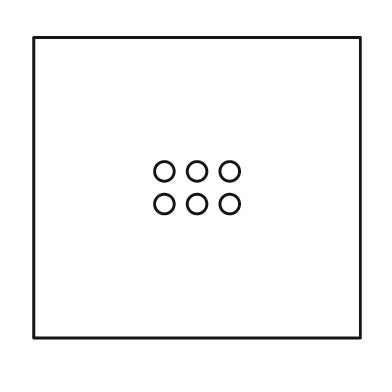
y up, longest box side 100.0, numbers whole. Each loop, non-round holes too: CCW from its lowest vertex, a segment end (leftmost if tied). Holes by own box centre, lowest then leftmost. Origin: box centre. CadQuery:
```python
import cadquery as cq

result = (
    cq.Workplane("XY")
    .moveTo(-50.0, -46.0)
    .lineTo(50.0, -46.0)
    .lineTo(50.0, 46.0)
    .lineTo(-50.0, 46.0)
    .close()
    .moveTo(-10.0, -5.0)
    .circle(3.0)
    .moveTo(0.0, -5.0)
    .circle(3.0)
    .moveTo(10.0, -5.0)
    .circle(3.0)
    .moveTo(-10.0, 5.0)
    .circle(3.0)
    .moveTo(0.0, 5.0)
    .circle(3.0)
    .moveTo(10.0, 5.0)
    .circle(3.0)
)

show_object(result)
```